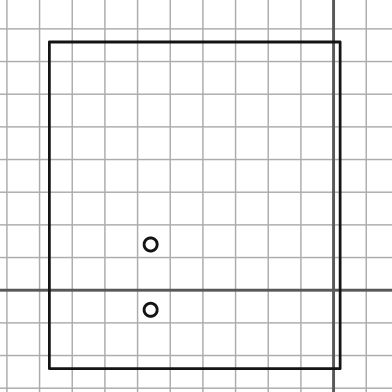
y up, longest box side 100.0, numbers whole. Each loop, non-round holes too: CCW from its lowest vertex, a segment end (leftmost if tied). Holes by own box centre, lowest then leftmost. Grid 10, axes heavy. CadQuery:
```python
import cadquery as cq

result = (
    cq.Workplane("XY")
    .moveTo(-87.0, -24.0)
    .lineTo(2.0, -24.0)
    .lineTo(2.0, 76.0)
    .lineTo(-87.0, 76.0)
    .close()
    .moveTo(-56.0, -6.0)
    .circle(2.0)
    .moveTo(-56.0, 14.0)
    .circle(2.0)
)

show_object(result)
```